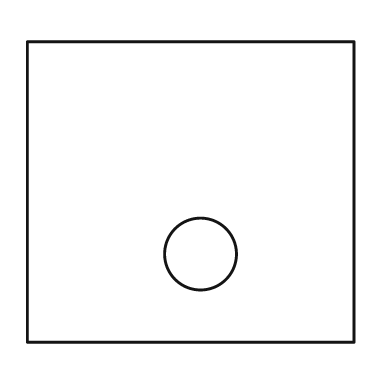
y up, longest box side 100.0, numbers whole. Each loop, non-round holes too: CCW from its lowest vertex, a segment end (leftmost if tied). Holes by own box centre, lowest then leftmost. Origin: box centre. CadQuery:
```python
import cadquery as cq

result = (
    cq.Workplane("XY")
    .moveTo(-50.0, -46.0)
    .lineTo(50.0, -46.0)
    .lineTo(50.0, 46.0)
    .lineTo(-50.0, 46.0)
    .close()
    .moveTo(3.0, -19.0)
    .circle(11.0)
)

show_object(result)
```